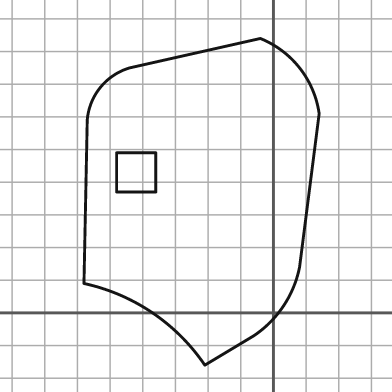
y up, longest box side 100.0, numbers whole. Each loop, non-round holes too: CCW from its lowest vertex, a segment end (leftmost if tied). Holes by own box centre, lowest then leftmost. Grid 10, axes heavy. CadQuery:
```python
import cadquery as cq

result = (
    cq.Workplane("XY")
    .moveTo(-21.0, -16.0)
    .lineTo(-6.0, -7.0)
    .threePointArc((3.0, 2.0), (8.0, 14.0))
    .lineTo(14.0, 61.0)
    .threePointArc((8.0, 75.0), (-4.0, 84.0))
    .lineTo(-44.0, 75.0)
    .threePointArc((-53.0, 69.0), (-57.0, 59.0))
    .lineTo(-58.0, 9.0)
    .threePointArc((-37.0, 0.0), (-21.0, -16.0))
    .close()
    .moveTo(-48.0, 37.0)
    .lineTo(-36.0, 37.0)
    .lineTo(-36.0, 49.0)
    .lineTo(-48.0, 49.0)
    .close()
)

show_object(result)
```